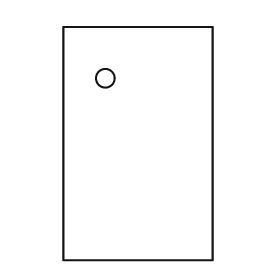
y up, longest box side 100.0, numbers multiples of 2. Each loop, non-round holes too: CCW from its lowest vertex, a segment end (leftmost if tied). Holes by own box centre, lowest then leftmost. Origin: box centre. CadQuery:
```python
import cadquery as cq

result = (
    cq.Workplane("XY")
    .moveTo(-32.0, -50.0)
    .lineTo(32.0, -50.0)
    .lineTo(32.0, 50.0)
    .lineTo(-32.0, 50.0)
    .close()
    .moveTo(-14.0, 28.0)
    .circle(4.0)
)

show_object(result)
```